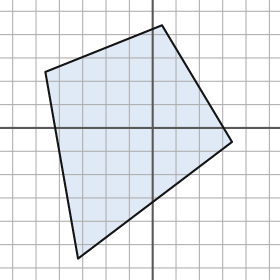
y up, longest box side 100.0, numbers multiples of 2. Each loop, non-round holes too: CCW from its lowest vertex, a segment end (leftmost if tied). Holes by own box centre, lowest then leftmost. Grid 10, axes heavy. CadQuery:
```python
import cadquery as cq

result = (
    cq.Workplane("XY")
    .moveTo(-32.0, -56.0)
    .lineTo(34.0, -6.0)
    .lineTo(4.0, 44.0)
    .lineTo(-46.0, 24.0)
    .close()
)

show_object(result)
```